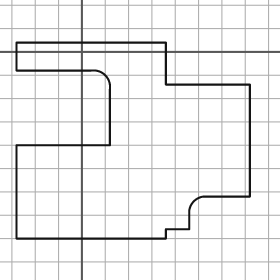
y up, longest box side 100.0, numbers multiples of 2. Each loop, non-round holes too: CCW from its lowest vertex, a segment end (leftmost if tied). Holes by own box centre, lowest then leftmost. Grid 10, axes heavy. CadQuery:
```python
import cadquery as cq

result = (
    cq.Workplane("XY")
    .moveTo(-28.0, -80.0)
    .lineTo(36.0, -80.0)
    .lineTo(36.0, -76.0)
    .lineTo(46.0, -76.0)
    .lineTo(46.0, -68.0)
    .threePointArc((48.0, -64.0), (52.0, -62.0))
    .lineTo(72.0, -62.0)
    .lineTo(72.0, -14.0)
    .lineTo(36.0, -14.0)
    .lineTo(36.0, 4.0)
    .lineTo(-28.0, 4.0)
    .lineTo(-28.0, -8.0)
    .lineTo(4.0, -8.0)
    .threePointArc((10.0, -10.0), (12.0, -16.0))
    .lineTo(12.0, -40.0)
    .lineTo(-28.0, -40.0)
    .close()
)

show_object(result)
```